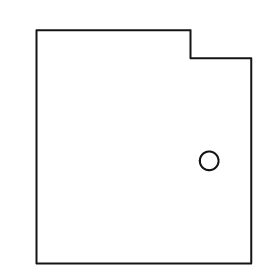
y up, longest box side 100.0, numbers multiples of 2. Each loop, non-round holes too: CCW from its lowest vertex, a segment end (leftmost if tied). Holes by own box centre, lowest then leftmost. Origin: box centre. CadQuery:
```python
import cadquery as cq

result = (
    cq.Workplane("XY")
    .moveTo(-46.0, -50.0)
    .lineTo(46.0, -50.0)
    .lineTo(46.0, 38.0)
    .lineTo(20.0, 38.0)
    .lineTo(20.0, 50.0)
    .lineTo(-46.0, 50.0)
    .close()
    .moveTo(28.0, -6.0)
    .circle(4.0)
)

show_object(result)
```